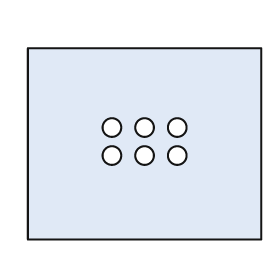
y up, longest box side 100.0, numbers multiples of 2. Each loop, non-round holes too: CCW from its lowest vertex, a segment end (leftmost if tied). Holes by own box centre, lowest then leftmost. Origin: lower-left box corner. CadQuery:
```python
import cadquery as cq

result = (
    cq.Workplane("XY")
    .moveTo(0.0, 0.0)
    .lineTo(100.0, 0.0)
    .lineTo(100.0, 82.0)
    .lineTo(0.0, 82.0)
    .close()
    .moveTo(36.0, 36.0)
    .circle(4.0)
    .moveTo(50.0, 36.0)
    .circle(4.0)
    .moveTo(64.0, 36.0)
    .circle(4.0)
    .moveTo(36.0, 48.0)
    .circle(4.0)
    .moveTo(50.0, 48.0)
    .circle(4.0)
    .moveTo(64.0, 48.0)
    .circle(4.0)
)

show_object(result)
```